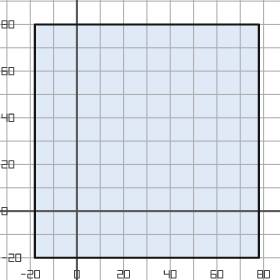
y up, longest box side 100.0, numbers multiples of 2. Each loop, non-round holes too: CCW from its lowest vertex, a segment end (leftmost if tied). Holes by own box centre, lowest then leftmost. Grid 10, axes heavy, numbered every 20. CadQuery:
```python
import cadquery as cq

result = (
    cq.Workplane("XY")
    .moveTo(-18.0, -20.0)
    .lineTo(78.0, -20.0)
    .lineTo(78.0, 80.0)
    .lineTo(-18.0, 80.0)
    .close()
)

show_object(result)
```